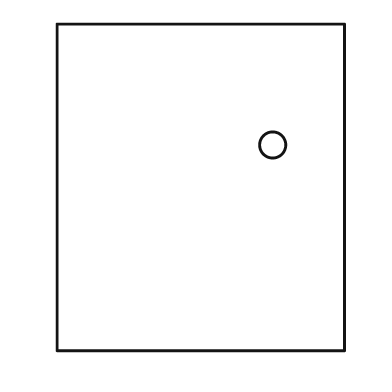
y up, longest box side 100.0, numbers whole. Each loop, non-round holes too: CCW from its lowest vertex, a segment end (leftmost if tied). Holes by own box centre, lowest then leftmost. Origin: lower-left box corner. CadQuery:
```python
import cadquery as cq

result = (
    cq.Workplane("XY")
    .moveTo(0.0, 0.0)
    .lineTo(88.0, 0.0)
    .lineTo(88.0, 100.0)
    .lineTo(0.0, 100.0)
    .close()
    .moveTo(66.0, 63.0)
    .circle(4.0)
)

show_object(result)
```